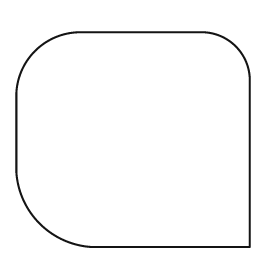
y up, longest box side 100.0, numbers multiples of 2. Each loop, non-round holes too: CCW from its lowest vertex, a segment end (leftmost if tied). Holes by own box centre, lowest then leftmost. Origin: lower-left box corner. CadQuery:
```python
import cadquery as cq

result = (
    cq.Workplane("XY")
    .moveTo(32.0, 0.0)
    .lineTo(100.0, 0.0)
    .lineTo(100.0, 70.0)
    .threePointArc((94.0, 86.0), (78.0, 92.0))
    .lineTo(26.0, 92.0)
    .threePointArc((8.0, 84.0), (0.0, 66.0))
    .lineTo(0.0, 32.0)
    .threePointArc((10.0, 10.0), (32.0, 0.0))
    .close()
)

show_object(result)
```